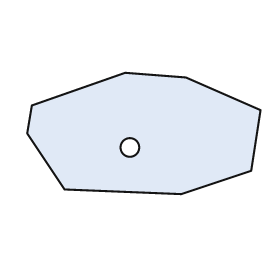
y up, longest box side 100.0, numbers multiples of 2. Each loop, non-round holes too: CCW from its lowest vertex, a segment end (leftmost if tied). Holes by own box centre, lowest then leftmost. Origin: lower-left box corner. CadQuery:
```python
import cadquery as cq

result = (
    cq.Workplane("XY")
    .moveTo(66.0, 0.0)
    .lineTo(96.0, 10.0)
    .lineTo(100.0, 36.0)
    .lineTo(68.0, 50.0)
    .lineTo(42.0, 52.0)
    .lineTo(2.0, 38.0)
    .lineTo(0.0, 26.0)
    .lineTo(16.0, 2.0)
    .close()
    .moveTo(44.0, 20.0)
    .circle(4.0)
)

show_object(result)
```